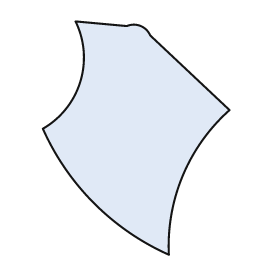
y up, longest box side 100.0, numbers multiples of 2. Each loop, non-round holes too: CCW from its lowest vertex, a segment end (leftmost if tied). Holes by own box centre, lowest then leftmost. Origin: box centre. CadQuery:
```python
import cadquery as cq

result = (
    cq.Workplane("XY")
    .moveTo(14.0, -50.0)
    .threePointArc((20.0, -16.0), (40.0, 12.0))
    .lineTo(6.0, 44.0)
    .threePointArc((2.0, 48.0), (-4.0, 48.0))
    .lineTo(-26.0, 50.0)
    .threePointArc((-24.0, 24.0), (-40.0, 4.0))
    .threePointArc((-18.0, -28.0), (14.0, -50.0))
    .close()
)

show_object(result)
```